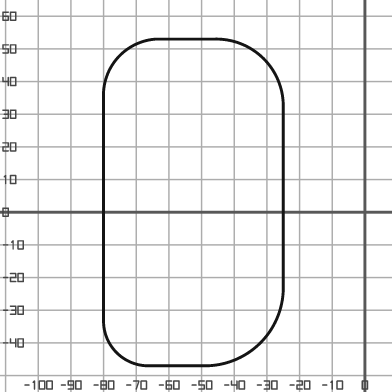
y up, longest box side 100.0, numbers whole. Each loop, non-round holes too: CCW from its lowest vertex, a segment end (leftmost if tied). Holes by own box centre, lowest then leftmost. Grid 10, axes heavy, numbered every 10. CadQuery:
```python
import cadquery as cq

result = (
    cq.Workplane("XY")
    .moveTo(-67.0, -47.0)
    .lineTo(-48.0, -47.0)
    .threePointArc((-32.0, -40.0), (-25.0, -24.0))
    .lineTo(-25.0, 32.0)
    .threePointArc((-31.0, 47.0), (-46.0, 53.0))
    .lineTo(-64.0, 53.0)
    .threePointArc((-75.0, 48.0), (-80.0, 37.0))
    .lineTo(-80.0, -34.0)
    .threePointArc((-76.0, -43.0), (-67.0, -47.0))
    .close()
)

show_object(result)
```